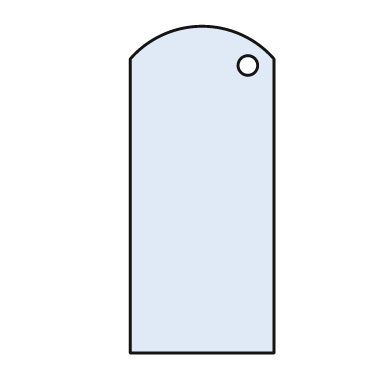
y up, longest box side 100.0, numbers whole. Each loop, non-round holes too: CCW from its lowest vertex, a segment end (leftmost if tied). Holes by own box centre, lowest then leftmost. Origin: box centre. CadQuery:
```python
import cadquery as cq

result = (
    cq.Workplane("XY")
    .moveTo(-22.0, -50.0)
    .lineTo(22.0, -50.0)
    .lineTo(22.0, 40.0)
    .threePointArc((0.0, 50.0), (-22.0, 40.0))
    .close()
    .moveTo(14.0, 38.0)
    .circle(3.0)
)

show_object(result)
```